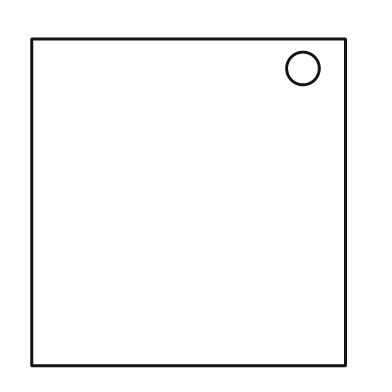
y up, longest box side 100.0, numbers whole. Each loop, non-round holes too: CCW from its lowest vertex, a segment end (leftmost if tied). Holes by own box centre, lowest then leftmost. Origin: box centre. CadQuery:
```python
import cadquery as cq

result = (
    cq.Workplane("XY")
    .moveTo(-48.0, -50.0)
    .lineTo(48.0, -50.0)
    .lineTo(48.0, 50.0)
    .lineTo(-48.0, 50.0)
    .close()
    .moveTo(35.0, 41.0)
    .circle(5.0)
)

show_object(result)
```